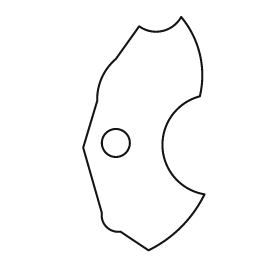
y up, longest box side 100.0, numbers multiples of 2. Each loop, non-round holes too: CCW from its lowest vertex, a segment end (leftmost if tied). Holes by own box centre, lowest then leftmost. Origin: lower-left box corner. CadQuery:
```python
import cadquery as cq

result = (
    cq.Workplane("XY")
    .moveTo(28.0, 0.0)
    .threePointArc((42.0, 10.0), (52.0, 24.0))
    .threePointArc((34.0, 44.0), (50.0, 66.0))
    .threePointArc((50.0, 84.0), (42.0, 100.0))
    .threePointArc((34.0, 94.0), (24.0, 96.0))
    .lineTo(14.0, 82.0)
    .threePointArc((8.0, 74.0), (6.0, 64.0))
    .lineTo(0.0, 44.0)
    .lineTo(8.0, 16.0)
    .threePointArc((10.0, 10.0), (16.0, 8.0))
    .close()
    .moveTo(14.0, 46.0)
    .circle(6.0)
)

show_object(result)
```